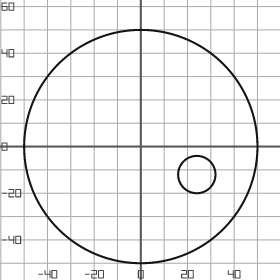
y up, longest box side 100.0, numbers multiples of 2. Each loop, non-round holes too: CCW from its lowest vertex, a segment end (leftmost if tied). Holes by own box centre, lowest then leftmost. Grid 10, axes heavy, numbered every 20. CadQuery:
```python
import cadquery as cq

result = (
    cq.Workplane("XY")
    .moveTo(0.0, 0.0)
    .circle(50.0)
    .moveTo(24.0, -12.0)
    .circle(8.0)
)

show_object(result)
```